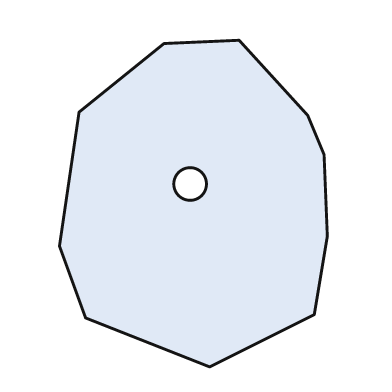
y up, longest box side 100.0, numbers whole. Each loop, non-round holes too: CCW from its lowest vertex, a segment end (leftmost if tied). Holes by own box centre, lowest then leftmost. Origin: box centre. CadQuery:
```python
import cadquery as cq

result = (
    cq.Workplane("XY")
    .moveTo(5.0, -50.0)
    .lineTo(37.0, -34.0)
    .lineTo(41.0, -10.0)
    .lineTo(40.0, 15.0)
    .lineTo(35.0, 27.0)
    .lineTo(14.0, 50.0)
    .lineTo(-9.0, 49.0)
    .lineTo(-35.0, 28.0)
    .lineTo(-41.0, -13.0)
    .lineTo(-33.0, -35.0)
    .close()
    .moveTo(-1.0, 6.0)
    .circle(5.0)
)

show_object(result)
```